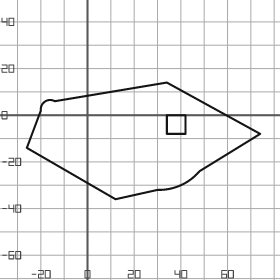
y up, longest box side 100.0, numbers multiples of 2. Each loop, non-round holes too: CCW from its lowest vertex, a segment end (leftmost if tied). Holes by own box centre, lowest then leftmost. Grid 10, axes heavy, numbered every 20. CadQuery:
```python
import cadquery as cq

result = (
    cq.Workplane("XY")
    .moveTo(12.0, -36.0)
    .lineTo(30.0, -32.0)
    .threePointArc((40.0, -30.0), (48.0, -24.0))
    .lineTo(74.0, -8.0)
    .lineTo(34.0, 14.0)
    .lineTo(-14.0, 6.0)
    .threePointArc((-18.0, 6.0), (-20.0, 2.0))
    .lineTo(-26.0, -14.0)
    .close()
    .moveTo(34.0, -8.0)
    .lineTo(42.0, -8.0)
    .lineTo(42.0, 0.0)
    .lineTo(34.0, 0.0)
    .close()
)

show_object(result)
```